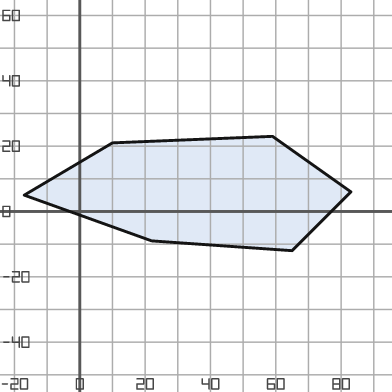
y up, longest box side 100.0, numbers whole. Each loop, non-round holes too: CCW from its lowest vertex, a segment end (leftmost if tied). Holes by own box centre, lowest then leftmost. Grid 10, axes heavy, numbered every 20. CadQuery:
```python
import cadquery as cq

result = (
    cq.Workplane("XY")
    .moveTo(65.0, -12.0)
    .lineTo(83.0, 6.0)
    .lineTo(59.0, 23.0)
    .lineTo(10.0, 21.0)
    .lineTo(-17.0, 5.0)
    .lineTo(22.0, -9.0)
    .close()
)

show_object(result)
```